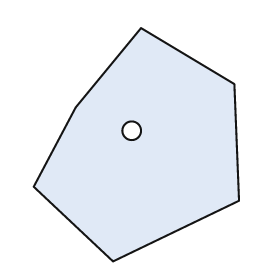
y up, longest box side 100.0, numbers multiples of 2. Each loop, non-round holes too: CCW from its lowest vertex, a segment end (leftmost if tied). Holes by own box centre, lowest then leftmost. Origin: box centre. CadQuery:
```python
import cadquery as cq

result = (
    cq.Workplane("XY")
    .moveTo(-10.0, -50.0)
    .lineTo(44.0, -24.0)
    .lineTo(42.0, 26.0)
    .lineTo(2.0, 50.0)
    .lineTo(-26.0, 16.0)
    .lineTo(-44.0, -18.0)
    .close()
    .moveTo(-2.0, 6.0)
    .circle(4.0)
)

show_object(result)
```